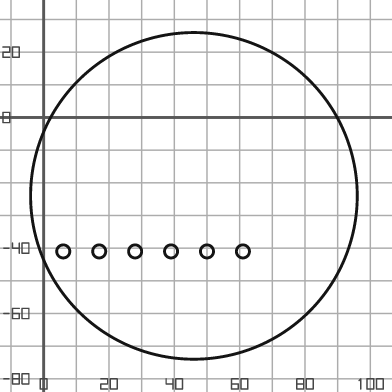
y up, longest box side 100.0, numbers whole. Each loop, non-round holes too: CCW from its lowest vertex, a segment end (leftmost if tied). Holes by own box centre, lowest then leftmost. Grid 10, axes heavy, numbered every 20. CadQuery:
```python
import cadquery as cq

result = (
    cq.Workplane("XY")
    .moveTo(46.0, -24.0)
    .circle(50.0)
    .moveTo(6.0, -41.0)
    .circle(2.0)
    .moveTo(17.0, -41.0)
    .circle(2.0)
    .moveTo(28.0, -41.0)
    .circle(2.0)
    .moveTo(39.0, -41.0)
    .circle(2.0)
    .moveTo(50.0, -41.0)
    .circle(2.0)
    .moveTo(61.0, -41.0)
    .circle(2.0)
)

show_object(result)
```